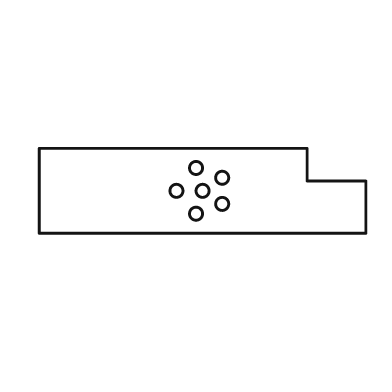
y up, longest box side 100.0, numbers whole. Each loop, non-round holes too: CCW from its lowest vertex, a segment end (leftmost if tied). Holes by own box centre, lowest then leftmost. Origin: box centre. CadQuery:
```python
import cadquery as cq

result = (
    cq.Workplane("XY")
    .moveTo(-50.0, -13.0)
    .lineTo(50.0, -13.0)
    .lineTo(50.0, 3.0)
    .lineTo(32.0, 3.0)
    .lineTo(32.0, 13.0)
    .lineTo(-50.0, 13.0)
    .close()
    .moveTo(-2.0, -7.0)
    .circle(2.0)
    .moveTo(6.0, -4.0)
    .circle(2.0)
    .moveTo(-8.0, 0.0)
    .circle(2.0)
    .moveTo(0.0, 0.0)
    .circle(2.0)
    .moveTo(6.0, 4.0)
    .circle(2.0)
    .moveTo(-2.0, 7.0)
    .circle(2.0)
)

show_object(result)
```